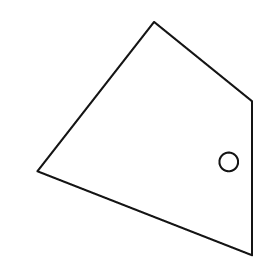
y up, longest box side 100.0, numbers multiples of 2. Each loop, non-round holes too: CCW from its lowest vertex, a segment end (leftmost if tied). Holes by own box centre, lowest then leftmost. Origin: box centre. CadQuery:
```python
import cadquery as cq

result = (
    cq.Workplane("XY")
    .moveTo(46.0, -50.0)
    .lineTo(46.0, 16.0)
    .lineTo(4.0, 50.0)
    .lineTo(-46.0, -14.0)
    .close()
    .moveTo(36.0, -10.0)
    .circle(4.0)
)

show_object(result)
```